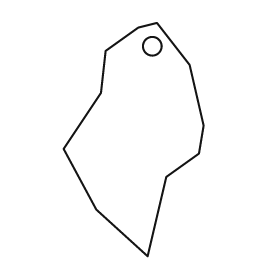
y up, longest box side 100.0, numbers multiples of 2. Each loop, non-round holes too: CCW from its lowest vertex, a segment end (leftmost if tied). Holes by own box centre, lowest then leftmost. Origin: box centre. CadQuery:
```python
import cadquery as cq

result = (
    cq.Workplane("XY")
    .moveTo(6.0, -50.0)
    .lineTo(14.0, -16.0)
    .lineTo(28.0, -6.0)
    .lineTo(30.0, 6.0)
    .lineTo(24.0, 32.0)
    .lineTo(10.0, 50.0)
    .lineTo(2.0, 48.0)
    .lineTo(-12.0, 38.0)
    .lineTo(-14.0, 20.0)
    .lineTo(-30.0, -4.0)
    .lineTo(-16.0, -30.0)
    .close()
    .moveTo(8.0, 40.0)
    .circle(4.0)
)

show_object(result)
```